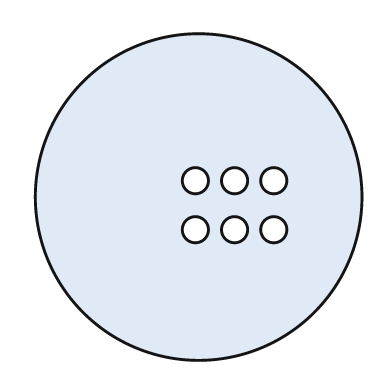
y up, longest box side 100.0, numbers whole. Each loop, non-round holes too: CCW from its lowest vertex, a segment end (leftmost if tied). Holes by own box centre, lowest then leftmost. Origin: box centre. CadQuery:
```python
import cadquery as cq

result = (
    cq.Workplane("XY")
    .moveTo(0.0, 0.0)
    .circle(50.0)
    .moveTo(-1.0, -10.0)
    .circle(4.0)
    .moveTo(11.0, -10.0)
    .circle(4.0)
    .moveTo(23.0, -10.0)
    .circle(4.0)
    .moveTo(-1.0, 5.0)
    .circle(4.0)
    .moveTo(11.0, 5.0)
    .circle(4.0)
    .moveTo(23.0, 5.0)
    .circle(4.0)
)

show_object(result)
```